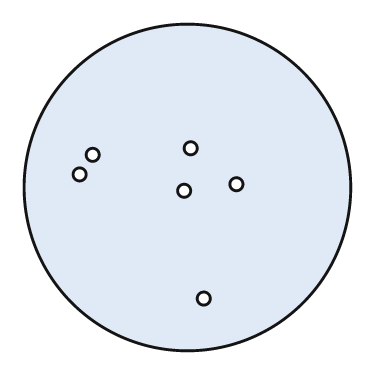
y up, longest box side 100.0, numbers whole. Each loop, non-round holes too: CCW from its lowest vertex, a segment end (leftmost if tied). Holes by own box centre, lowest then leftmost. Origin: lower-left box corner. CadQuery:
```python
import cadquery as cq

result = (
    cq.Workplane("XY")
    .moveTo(50.0, 50.0)
    .circle(50.0)
    .moveTo(55.0, 16.0)
    .circle(2.0)
    .moveTo(49.0, 49.0)
    .circle(2.0)
    .moveTo(65.0, 51.0)
    .circle(2.0)
    .moveTo(17.0, 54.0)
    .circle(2.0)
    .moveTo(21.0, 60.0)
    .circle(2.0)
    .moveTo(51.0, 62.0)
    .circle(2.0)
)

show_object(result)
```